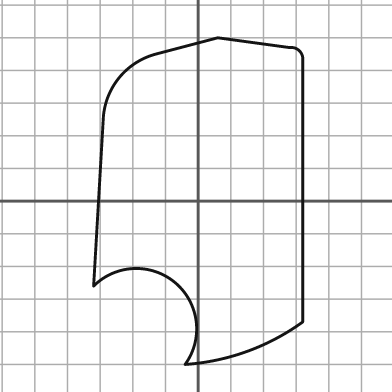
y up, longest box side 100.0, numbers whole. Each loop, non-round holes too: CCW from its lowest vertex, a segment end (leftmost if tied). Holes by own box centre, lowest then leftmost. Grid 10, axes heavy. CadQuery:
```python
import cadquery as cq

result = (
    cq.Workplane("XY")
    .moveTo(-4.0, -50.0)
    .threePointArc((15.0, -46.0), (32.0, -37.0))
    .lineTo(32.0, 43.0)
    .threePointArc((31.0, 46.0), (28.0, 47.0))
    .lineTo(6.0, 50.0)
    .lineTo(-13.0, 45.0)
    .threePointArc((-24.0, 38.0), (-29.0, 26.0))
    .lineTo(-32.0, -26.0)
    .threePointArc((-7.0, -25.0), (-4.0, -50.0))
    .close()
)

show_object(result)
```